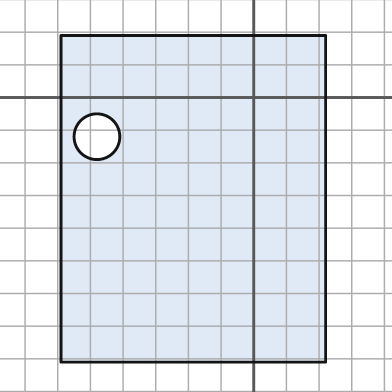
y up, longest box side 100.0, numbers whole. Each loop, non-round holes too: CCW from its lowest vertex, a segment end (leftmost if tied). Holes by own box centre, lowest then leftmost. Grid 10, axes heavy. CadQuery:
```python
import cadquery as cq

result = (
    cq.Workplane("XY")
    .moveTo(-59.0, -81.0)
    .lineTo(22.0, -81.0)
    .lineTo(22.0, 19.0)
    .lineTo(-59.0, 19.0)
    .close()
    .moveTo(-48.0, -12.0)
    .circle(7.0)
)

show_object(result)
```